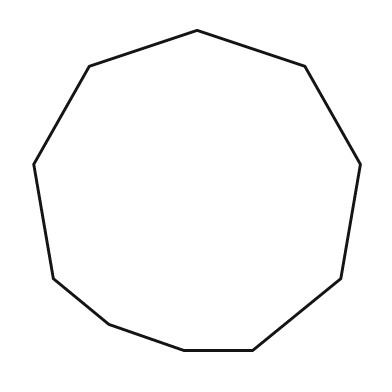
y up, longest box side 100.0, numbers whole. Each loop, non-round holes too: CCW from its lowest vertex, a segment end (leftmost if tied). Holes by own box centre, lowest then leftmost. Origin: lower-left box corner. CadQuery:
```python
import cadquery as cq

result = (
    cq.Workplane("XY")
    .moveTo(46.0, 0.0)
    .lineTo(67.0, 0.0)
    .lineTo(94.0, 22.0)
    .lineTo(100.0, 57.0)
    .lineTo(83.0, 87.0)
    .lineTo(50.0, 98.0)
    .lineTo(17.0, 87.0)
    .lineTo(0.0, 57.0)
    .lineTo(6.0, 22.0)
    .lineTo(23.0, 8.0)
    .close()
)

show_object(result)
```